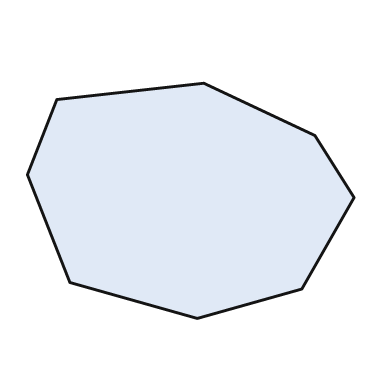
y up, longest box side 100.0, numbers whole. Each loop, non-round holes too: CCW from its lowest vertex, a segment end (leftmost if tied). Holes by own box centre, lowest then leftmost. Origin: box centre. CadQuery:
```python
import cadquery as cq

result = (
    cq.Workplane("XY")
    .moveTo(2.0, -36.0)
    .lineTo(34.0, -27.0)
    .lineTo(50.0, 1.0)
    .lineTo(38.0, 20.0)
    .lineTo(4.0, 36.0)
    .lineTo(-41.0, 31.0)
    .lineTo(-50.0, 8.0)
    .lineTo(-37.0, -25.0)
    .close()
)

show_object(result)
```